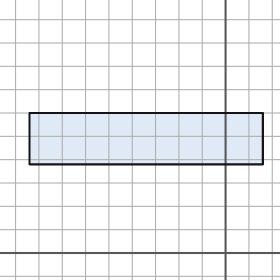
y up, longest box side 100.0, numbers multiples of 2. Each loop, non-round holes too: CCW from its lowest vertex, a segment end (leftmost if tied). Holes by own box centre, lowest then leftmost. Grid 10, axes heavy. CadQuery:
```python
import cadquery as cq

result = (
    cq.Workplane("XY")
    .moveTo(-84.0, 38.0)
    .lineTo(16.0, 38.0)
    .lineTo(16.0, 60.0)
    .lineTo(-84.0, 60.0)
    .close()
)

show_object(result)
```